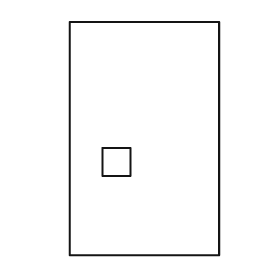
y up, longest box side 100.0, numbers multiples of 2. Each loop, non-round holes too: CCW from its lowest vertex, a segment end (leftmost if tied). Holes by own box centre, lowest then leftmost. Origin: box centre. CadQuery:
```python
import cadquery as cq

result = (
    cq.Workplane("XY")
    .moveTo(-32.0, -50.0)
    .lineTo(32.0, -50.0)
    .lineTo(32.0, 50.0)
    .lineTo(-32.0, 50.0)
    .close()
    .moveTo(-18.0, -16.0)
    .lineTo(-6.0, -16.0)
    .lineTo(-6.0, -4.0)
    .lineTo(-18.0, -4.0)
    .close()
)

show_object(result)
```